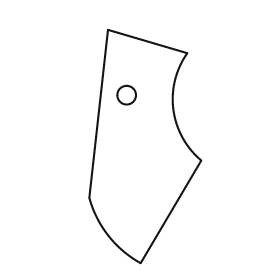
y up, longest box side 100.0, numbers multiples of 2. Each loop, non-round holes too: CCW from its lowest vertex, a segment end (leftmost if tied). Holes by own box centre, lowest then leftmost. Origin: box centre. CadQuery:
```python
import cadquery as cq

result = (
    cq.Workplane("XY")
    .moveTo(-2.0, -50.0)
    .lineTo(24.0, -6.0)
    .threePointArc((12.0, 16.0), (18.0, 40.0))
    .lineTo(-16.0, 50.0)
    .lineTo(-24.0, -22.0)
    .threePointArc((-16.0, -38.0), (-2.0, -50.0))
    .close()
    .moveTo(-8.0, 22.0)
    .circle(4.0)
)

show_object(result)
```